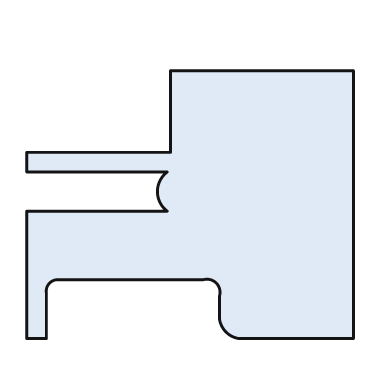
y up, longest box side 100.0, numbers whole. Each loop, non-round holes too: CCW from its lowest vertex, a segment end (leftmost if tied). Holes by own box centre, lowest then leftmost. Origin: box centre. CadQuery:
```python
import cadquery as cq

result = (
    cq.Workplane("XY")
    .moveTo(-50.0, -41.0)
    .lineTo(-44.0, -41.0)
    .lineTo(-44.0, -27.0)
    .threePointArc((-43.0, -24.0), (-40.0, -23.0))
    .lineTo(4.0, -23.0)
    .threePointArc((8.0, -24.0), (9.0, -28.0))
    .lineTo(9.0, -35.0)
    .threePointArc((11.0, -39.0), (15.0, -41.0))
    .lineTo(50.0, -41.0)
    .lineTo(50.0, 41.0)
    .lineTo(-6.0, 41.0)
    .lineTo(-6.0, 16.0)
    .lineTo(-50.0, 16.0)
    .lineTo(-50.0, 10.0)
    .lineTo(-7.0, 10.0)
    .threePointArc((-10.0, 4.0), (-7.0, -2.0))
    .lineTo(-50.0, -2.0)
    .close()
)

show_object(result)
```